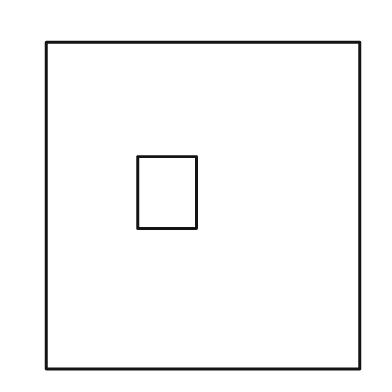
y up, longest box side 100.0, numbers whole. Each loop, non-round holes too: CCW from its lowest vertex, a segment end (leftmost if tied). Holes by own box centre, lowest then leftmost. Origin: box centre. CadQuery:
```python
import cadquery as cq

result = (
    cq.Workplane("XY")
    .moveTo(-48.0, -50.0)
    .lineTo(48.0, -50.0)
    .lineTo(48.0, 50.0)
    .lineTo(-48.0, 50.0)
    .close()
    .moveTo(-20.0, -7.0)
    .lineTo(-2.0, -7.0)
    .lineTo(-2.0, 15.0)
    .lineTo(-20.0, 15.0)
    .close()
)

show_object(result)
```